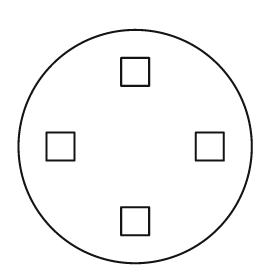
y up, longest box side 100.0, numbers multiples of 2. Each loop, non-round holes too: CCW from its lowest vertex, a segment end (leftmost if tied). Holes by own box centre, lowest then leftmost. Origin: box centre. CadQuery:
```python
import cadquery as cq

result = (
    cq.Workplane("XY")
    .moveTo(0.0, 0.0)
    .circle(50.0)
    .moveTo(-6.0, -38.0)
    .lineTo(6.0, -38.0)
    .lineTo(6.0, -26.0)
    .lineTo(-6.0, -26.0)
    .close()
    .moveTo(-38.0, -6.0)
    .lineTo(-26.0, -6.0)
    .lineTo(-26.0, 6.0)
    .lineTo(-38.0, 6.0)
    .close()
    .moveTo(26.0, -6.0)
    .lineTo(38.0, -6.0)
    .lineTo(38.0, 6.0)
    .lineTo(26.0, 6.0)
    .close()
    .moveTo(-6.0, 26.0)
    .lineTo(6.0, 26.0)
    .lineTo(6.0, 38.0)
    .lineTo(-6.0, 38.0)
    .close()
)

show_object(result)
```